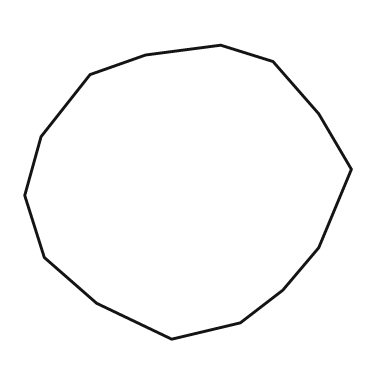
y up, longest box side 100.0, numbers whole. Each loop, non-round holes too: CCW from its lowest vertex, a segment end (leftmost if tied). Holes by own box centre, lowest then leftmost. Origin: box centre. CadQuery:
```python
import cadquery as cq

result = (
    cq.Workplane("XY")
    .moveTo(-5.0, -45.0)
    .lineTo(16.0, -40.0)
    .lineTo(29.0, -30.0)
    .lineTo(40.0, -17.0)
    .lineTo(50.0, 7.0)
    .lineTo(40.0, 24.0)
    .lineTo(26.0, 40.0)
    .lineTo(10.0, 45.0)
    .lineTo(-13.0, 42.0)
    .lineTo(-30.0, 36.0)
    .lineTo(-45.0, 17.0)
    .lineTo(-50.0, -1.0)
    .lineTo(-44.0, -20.0)
    .lineTo(-28.0, -34.0)
    .close()
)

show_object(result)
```